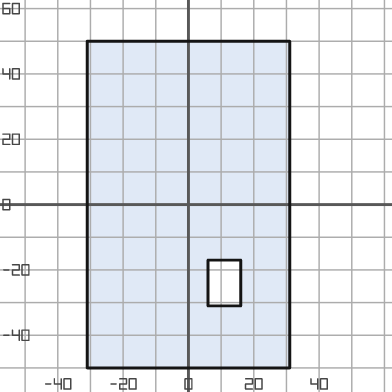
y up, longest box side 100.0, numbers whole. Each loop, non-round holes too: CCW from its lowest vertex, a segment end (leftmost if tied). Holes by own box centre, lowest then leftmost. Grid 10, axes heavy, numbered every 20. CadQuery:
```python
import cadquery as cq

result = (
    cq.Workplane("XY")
    .moveTo(-31.0, -50.0)
    .lineTo(31.0, -50.0)
    .lineTo(31.0, 50.0)
    .lineTo(-31.0, 50.0)
    .close()
    .moveTo(6.0, -31.0)
    .lineTo(16.0, -31.0)
    .lineTo(16.0, -17.0)
    .lineTo(6.0, -17.0)
    .close()
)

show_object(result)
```